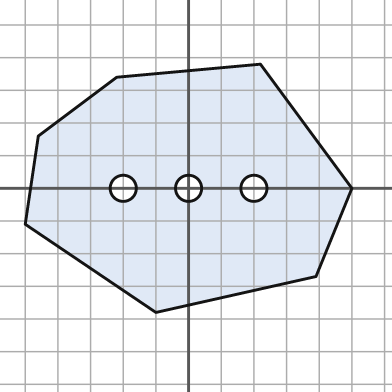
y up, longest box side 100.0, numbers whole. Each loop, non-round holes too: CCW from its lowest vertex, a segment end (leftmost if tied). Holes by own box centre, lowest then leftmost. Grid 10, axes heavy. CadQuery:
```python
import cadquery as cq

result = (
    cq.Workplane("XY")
    .moveTo(-10.0, -38.0)
    .lineTo(39.0, -27.0)
    .lineTo(50.0, 0.0)
    .lineTo(22.0, 38.0)
    .lineTo(-22.0, 34.0)
    .lineTo(-46.0, 16.0)
    .lineTo(-50.0, -11.0)
    .close()
    .moveTo(-20.0, 0.0)
    .circle(4.0)
    .moveTo(0.0, 0.0)
    .circle(4.0)
    .moveTo(20.0, 0.0)
    .circle(4.0)
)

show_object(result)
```